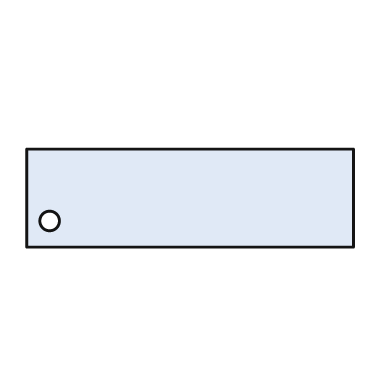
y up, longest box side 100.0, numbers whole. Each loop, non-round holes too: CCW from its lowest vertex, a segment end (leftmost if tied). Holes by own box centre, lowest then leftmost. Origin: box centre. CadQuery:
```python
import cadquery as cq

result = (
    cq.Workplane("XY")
    .moveTo(-50.0, -15.0)
    .lineTo(50.0, -15.0)
    .lineTo(50.0, 15.0)
    .lineTo(-50.0, 15.0)
    .close()
    .moveTo(-43.0, -7.0)
    .circle(3.0)
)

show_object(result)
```